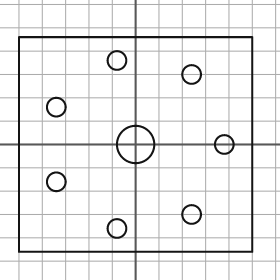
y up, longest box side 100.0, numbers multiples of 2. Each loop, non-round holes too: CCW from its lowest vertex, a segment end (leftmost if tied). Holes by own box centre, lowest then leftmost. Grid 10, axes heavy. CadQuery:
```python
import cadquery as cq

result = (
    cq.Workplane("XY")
    .moveTo(-50.0, -46.0)
    .lineTo(50.0, -46.0)
    .lineTo(50.0, 46.0)
    .lineTo(-50.0, 46.0)
    .close()
    .moveTo(-8.0, -36.0)
    .circle(4.0)
    .moveTo(24.0, -30.0)
    .circle(4.0)
    .moveTo(-34.0, -16.0)
    .circle(4.0)
    .moveTo(0.0, 0.0)
    .circle(8.0)
    .moveTo(38.0, 0.0)
    .circle(4.0)
    .moveTo(-34.0, 16.0)
    .circle(4.0)
    .moveTo(24.0, 30.0)
    .circle(4.0)
    .moveTo(-8.0, 36.0)
    .circle(4.0)
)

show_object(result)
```